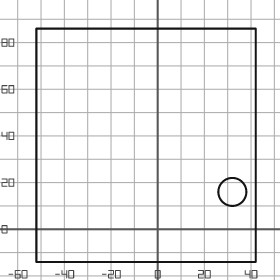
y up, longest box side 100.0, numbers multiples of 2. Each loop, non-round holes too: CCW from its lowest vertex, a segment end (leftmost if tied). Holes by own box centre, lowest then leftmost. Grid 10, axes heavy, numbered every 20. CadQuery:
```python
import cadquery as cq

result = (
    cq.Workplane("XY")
    .moveTo(-52.0, -14.0)
    .lineTo(42.0, -14.0)
    .lineTo(42.0, 86.0)
    .lineTo(-52.0, 86.0)
    .close()
    .moveTo(32.0, 16.0)
    .circle(6.0)
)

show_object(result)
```